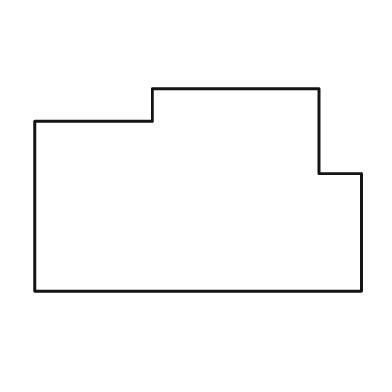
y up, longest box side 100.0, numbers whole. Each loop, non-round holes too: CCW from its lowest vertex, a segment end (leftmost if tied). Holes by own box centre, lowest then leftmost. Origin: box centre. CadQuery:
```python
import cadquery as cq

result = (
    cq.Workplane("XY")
    .moveTo(-50.0, -31.0)
    .lineTo(50.0, -31.0)
    .lineTo(50.0, 5.0)
    .lineTo(37.0, 5.0)
    .lineTo(37.0, 31.0)
    .lineTo(-14.0, 31.0)
    .lineTo(-14.0, 21.0)
    .lineTo(-50.0, 21.0)
    .close()
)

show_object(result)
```